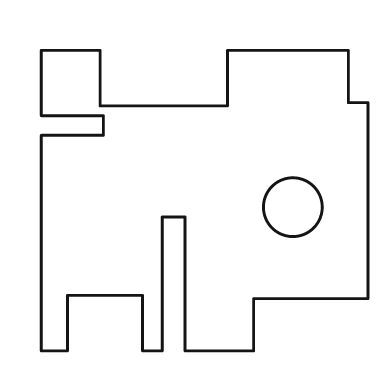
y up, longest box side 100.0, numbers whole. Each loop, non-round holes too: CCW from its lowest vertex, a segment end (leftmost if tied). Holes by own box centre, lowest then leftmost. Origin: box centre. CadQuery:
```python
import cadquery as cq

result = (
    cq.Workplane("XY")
    .moveTo(-50.0, -46.0)
    .lineTo(-42.0, -46.0)
    .lineTo(-42.0, -29.0)
    .lineTo(-19.0, -29.0)
    .lineTo(-19.0, -46.0)
    .lineTo(-13.0, -46.0)
    .lineTo(-13.0, -5.0)
    .lineTo(-6.0, -5.0)
    .lineTo(-6.0, -46.0)
    .lineTo(15.0, -46.0)
    .lineTo(15.0, -30.0)
    .lineTo(50.0, -30.0)
    .lineTo(50.0, 30.0)
    .lineTo(44.0, 30.0)
    .lineTo(44.0, 46.0)
    .lineTo(7.0, 46.0)
    .lineTo(7.0, 29.0)
    .lineTo(-32.0, 29.0)
    .lineTo(-32.0, 46.0)
    .lineTo(-50.0, 46.0)
    .lineTo(-50.0, 26.0)
    .lineTo(-31.0, 26.0)
    .lineTo(-31.0, 20.0)
    .lineTo(-50.0, 20.0)
    .close()
    .moveTo(27.0, -2.0)
    .circle(9.0)
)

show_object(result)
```